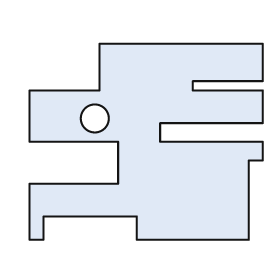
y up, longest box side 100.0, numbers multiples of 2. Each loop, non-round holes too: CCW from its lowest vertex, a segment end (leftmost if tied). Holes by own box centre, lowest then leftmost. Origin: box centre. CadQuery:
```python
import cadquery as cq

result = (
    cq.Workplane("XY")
    .moveTo(-50.0, -42.0)
    .lineTo(-44.0, -42.0)
    .lineTo(-44.0, -32.0)
    .lineTo(-4.0, -32.0)
    .lineTo(-4.0, -42.0)
    .lineTo(44.0, -42.0)
    .lineTo(44.0, -8.0)
    .lineTo(50.0, -8.0)
    .lineTo(50.0, 0.0)
    .lineTo(6.0, 0.0)
    .lineTo(6.0, 8.0)
    .lineTo(50.0, 8.0)
    .lineTo(50.0, 22.0)
    .lineTo(20.0, 22.0)
    .lineTo(20.0, 26.0)
    .lineTo(50.0, 26.0)
    .lineTo(50.0, 42.0)
    .lineTo(-20.0, 42.0)
    .lineTo(-20.0, 22.0)
    .lineTo(-50.0, 22.0)
    .lineTo(-50.0, 0.0)
    .lineTo(-12.0, 0.0)
    .lineTo(-12.0, -18.0)
    .lineTo(-50.0, -18.0)
    .close()
    .moveTo(-22.0, 10.0)
    .circle(6.0)
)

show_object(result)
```